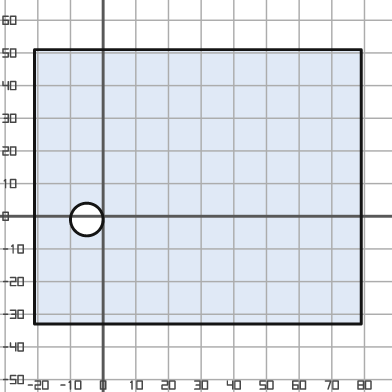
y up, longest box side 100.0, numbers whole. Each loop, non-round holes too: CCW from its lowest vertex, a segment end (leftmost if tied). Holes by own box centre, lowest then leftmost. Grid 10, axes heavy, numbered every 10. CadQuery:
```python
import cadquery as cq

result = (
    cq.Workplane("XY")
    .moveTo(-21.0, -33.0)
    .lineTo(79.0, -33.0)
    .lineTo(79.0, 51.0)
    .lineTo(-21.0, 51.0)
    .close()
    .moveTo(-5.0, -1.0)
    .circle(5.0)
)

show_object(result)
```